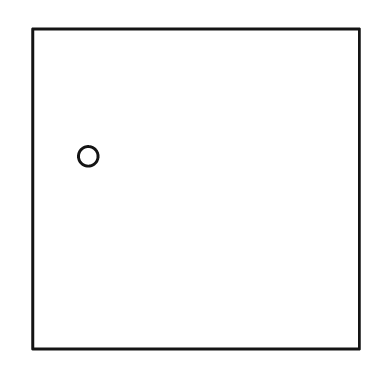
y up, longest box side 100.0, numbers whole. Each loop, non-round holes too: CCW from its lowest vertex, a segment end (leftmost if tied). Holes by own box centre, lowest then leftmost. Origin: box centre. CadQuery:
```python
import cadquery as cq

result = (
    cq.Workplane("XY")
    .moveTo(-50.0, -49.0)
    .lineTo(50.0, -49.0)
    .lineTo(50.0, 49.0)
    .lineTo(-50.0, 49.0)
    .close()
    .moveTo(-33.0, 10.0)
    .circle(3.0)
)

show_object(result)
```